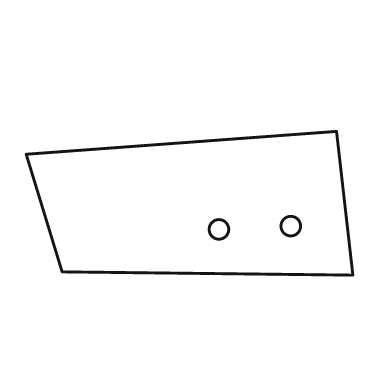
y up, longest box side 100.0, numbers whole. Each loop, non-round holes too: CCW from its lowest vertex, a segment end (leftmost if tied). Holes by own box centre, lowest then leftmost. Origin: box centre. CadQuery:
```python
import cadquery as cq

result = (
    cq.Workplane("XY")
    .moveTo(50.0, -22.0)
    .lineTo(45.0, 22.0)
    .lineTo(-50.0, 15.0)
    .lineTo(-39.0, -21.0)
    .close()
    .moveTo(9.0, -8.0)
    .circle(3.0)
    .moveTo(31.0, -7.0)
    .circle(3.0)
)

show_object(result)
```